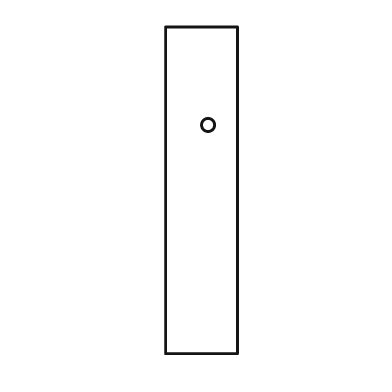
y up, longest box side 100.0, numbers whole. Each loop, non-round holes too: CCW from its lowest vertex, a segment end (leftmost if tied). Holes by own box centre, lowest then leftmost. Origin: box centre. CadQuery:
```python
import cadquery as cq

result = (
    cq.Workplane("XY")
    .moveTo(-11.0, -50.0)
    .lineTo(11.0, -50.0)
    .lineTo(11.0, 50.0)
    .lineTo(-11.0, 50.0)
    .close()
    .moveTo(2.0, 20.0)
    .circle(2.0)
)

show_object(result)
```